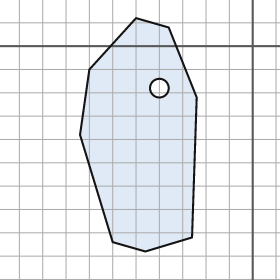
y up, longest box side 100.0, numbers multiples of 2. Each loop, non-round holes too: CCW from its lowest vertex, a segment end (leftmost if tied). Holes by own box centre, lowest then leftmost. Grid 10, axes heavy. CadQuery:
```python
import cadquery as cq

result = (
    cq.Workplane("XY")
    .moveTo(-46.0, -88.0)
    .lineTo(-26.0, -82.0)
    .lineTo(-24.0, -22.0)
    .lineTo(-36.0, 8.0)
    .lineTo(-50.0, 12.0)
    .lineTo(-70.0, -10.0)
    .lineTo(-74.0, -38.0)
    .lineTo(-60.0, -84.0)
    .close()
    .moveTo(-40.0, -18.0)
    .circle(4.0)
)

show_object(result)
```